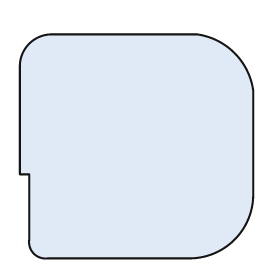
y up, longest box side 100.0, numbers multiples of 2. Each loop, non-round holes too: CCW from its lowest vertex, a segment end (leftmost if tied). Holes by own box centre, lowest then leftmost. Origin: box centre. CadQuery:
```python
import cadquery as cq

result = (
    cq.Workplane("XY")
    .moveTo(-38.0, -48.0)
    .lineTo(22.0, -48.0)
    .threePointArc((42.0, -40.0), (50.0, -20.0))
    .lineTo(50.0, 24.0)
    .threePointArc((42.0, 40.0), (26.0, 48.0))
    .lineTo(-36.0, 48.0)
    .threePointArc((-46.0, 44.0), (-50.0, 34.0))
    .lineTo(-50.0, -12.0)
    .lineTo(-46.0, -12.0)
    .lineTo(-46.0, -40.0)
    .threePointArc((-44.0, -46.0), (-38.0, -48.0))
    .close()
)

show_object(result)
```